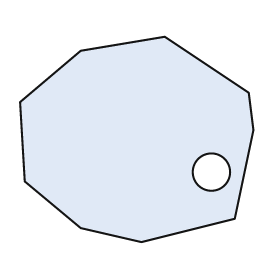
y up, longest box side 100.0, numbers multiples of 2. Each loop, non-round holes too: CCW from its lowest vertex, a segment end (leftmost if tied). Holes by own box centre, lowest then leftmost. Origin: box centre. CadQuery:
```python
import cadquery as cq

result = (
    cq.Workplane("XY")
    .moveTo(2.0, -44.0)
    .lineTo(42.0, -34.0)
    .lineTo(50.0, 4.0)
    .lineTo(48.0, 20.0)
    .lineTo(12.0, 44.0)
    .lineTo(-24.0, 38.0)
    .lineTo(-50.0, 16.0)
    .lineTo(-48.0, -18.0)
    .lineTo(-24.0, -38.0)
    .close()
    .moveTo(32.0, -14.0)
    .circle(8.0)
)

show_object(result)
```